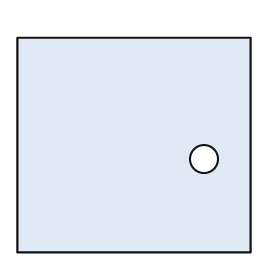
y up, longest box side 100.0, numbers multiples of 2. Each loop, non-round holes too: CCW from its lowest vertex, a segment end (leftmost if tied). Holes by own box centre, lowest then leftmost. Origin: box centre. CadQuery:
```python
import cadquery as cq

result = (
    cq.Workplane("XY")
    .moveTo(-50.0, -46.0)
    .lineTo(50.0, -46.0)
    .lineTo(50.0, 46.0)
    .lineTo(-50.0, 46.0)
    .close()
    .moveTo(30.0, -6.0)
    .circle(6.0)
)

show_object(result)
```